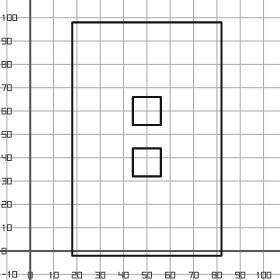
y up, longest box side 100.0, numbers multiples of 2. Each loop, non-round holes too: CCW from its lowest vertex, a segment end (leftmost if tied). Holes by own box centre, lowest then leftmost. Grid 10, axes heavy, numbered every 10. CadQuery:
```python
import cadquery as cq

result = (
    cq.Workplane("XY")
    .moveTo(18.0, -2.0)
    .lineTo(82.0, -2.0)
    .lineTo(82.0, 98.0)
    .lineTo(18.0, 98.0)
    .close()
    .moveTo(44.0, 32.0)
    .lineTo(56.0, 32.0)
    .lineTo(56.0, 44.0)
    .lineTo(44.0, 44.0)
    .close()
    .moveTo(44.0, 54.0)
    .lineTo(56.0, 54.0)
    .lineTo(56.0, 66.0)
    .lineTo(44.0, 66.0)
    .close()
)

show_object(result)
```